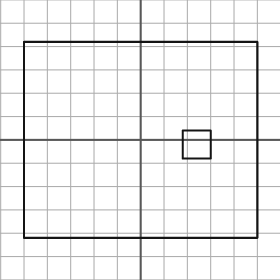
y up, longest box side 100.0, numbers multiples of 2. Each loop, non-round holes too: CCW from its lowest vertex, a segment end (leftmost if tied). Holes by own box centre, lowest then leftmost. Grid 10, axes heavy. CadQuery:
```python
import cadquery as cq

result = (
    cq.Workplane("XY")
    .moveTo(-50.0, -42.0)
    .lineTo(50.0, -42.0)
    .lineTo(50.0, 42.0)
    .lineTo(-50.0, 42.0)
    .close()
    .moveTo(18.0, -8.0)
    .lineTo(30.0, -8.0)
    .lineTo(30.0, 4.0)
    .lineTo(18.0, 4.0)
    .close()
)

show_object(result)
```